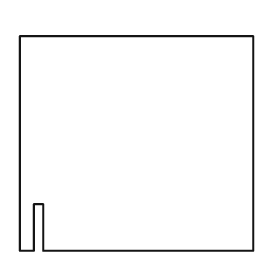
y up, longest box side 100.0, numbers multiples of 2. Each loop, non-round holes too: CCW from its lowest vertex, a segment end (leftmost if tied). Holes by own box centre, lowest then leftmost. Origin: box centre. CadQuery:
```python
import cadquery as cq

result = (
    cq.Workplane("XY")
    .moveTo(-50.0, -46.0)
    .lineTo(-44.0, -46.0)
    .lineTo(-44.0, -26.0)
    .lineTo(-40.0, -26.0)
    .lineTo(-40.0, -46.0)
    .lineTo(50.0, -46.0)
    .lineTo(50.0, 46.0)
    .lineTo(-50.0, 46.0)
    .close()
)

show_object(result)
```